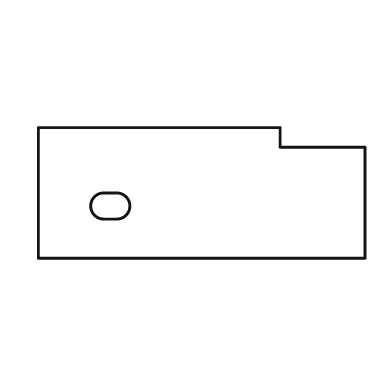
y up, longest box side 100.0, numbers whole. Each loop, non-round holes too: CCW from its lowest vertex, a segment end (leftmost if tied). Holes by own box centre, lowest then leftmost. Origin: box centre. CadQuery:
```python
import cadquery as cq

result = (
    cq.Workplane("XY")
    .moveTo(-50.0, -20.0)
    .lineTo(50.0, -20.0)
    .lineTo(50.0, 14.0)
    .lineTo(24.0, 14.0)
    .lineTo(24.0, 20.0)
    .lineTo(-50.0, 20.0)
    .close()
    .moveTo(-30.0, -8.0)
    .lineTo(-26.0, -8.0)
    .threePointArc((-22.0, -4.0), (-26.0, 0.0))
    .lineTo(-30.0, 0.0)
    .threePointArc((-34.0, -4.0), (-30.0, -8.0))
    .close()
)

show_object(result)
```